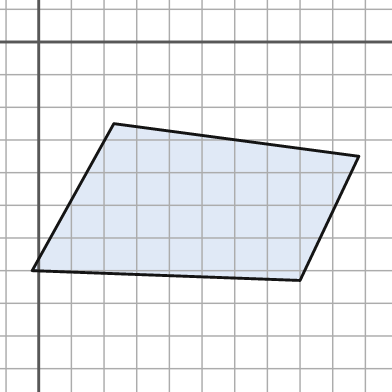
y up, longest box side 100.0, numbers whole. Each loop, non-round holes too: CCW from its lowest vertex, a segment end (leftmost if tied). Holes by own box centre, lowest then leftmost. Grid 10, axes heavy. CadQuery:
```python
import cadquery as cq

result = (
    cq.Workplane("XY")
    .moveTo(80.0, -73.0)
    .lineTo(98.0, -35.0)
    .lineTo(23.0, -25.0)
    .lineTo(-2.0, -70.0)
    .close()
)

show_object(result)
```